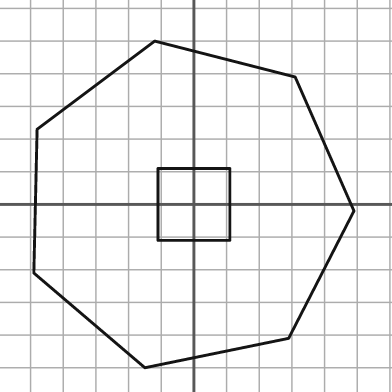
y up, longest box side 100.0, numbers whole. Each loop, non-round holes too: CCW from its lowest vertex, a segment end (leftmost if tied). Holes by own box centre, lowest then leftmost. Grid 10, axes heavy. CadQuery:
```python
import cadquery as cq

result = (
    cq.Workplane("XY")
    .moveTo(-15.0, -50.0)
    .lineTo(29.0, -41.0)
    .lineTo(49.0, -2.0)
    .lineTo(31.0, 39.0)
    .lineTo(-12.0, 50.0)
    .lineTo(-48.0, 23.0)
    .lineTo(-49.0, -21.0)
    .close()
    .moveTo(-11.0, -11.0)
    .lineTo(11.0, -11.0)
    .lineTo(11.0, 11.0)
    .lineTo(-11.0, 11.0)
    .close()
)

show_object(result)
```